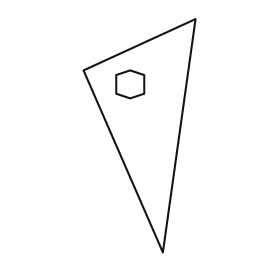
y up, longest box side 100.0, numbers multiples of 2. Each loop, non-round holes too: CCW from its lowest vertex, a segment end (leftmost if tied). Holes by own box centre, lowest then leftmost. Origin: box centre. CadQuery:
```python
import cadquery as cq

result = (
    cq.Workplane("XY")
    .moveTo(10.0, -50.0)
    .lineTo(24.0, 50.0)
    .lineTo(-24.0, 28.0)
    .close()
    .moveTo(-4.0, 16.0)
    .lineTo(2.0, 18.0)
    .lineTo(2.0, 26.0)
    .lineTo(-4.0, 28.0)
    .lineTo(-10.0, 26.0)
    .lineTo(-10.0, 18.0)
    .close()
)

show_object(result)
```